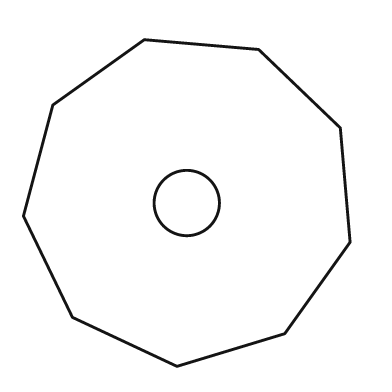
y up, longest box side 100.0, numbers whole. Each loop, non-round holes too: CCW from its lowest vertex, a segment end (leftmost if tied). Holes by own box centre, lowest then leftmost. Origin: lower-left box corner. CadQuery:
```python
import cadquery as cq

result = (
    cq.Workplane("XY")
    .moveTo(47.0, 0.0)
    .lineTo(80.0, 10.0)
    .lineTo(100.0, 38.0)
    .lineTo(97.0, 73.0)
    .lineTo(72.0, 97.0)
    .lineTo(37.0, 100.0)
    .lineTo(9.0, 80.0)
    .lineTo(0.0, 46.0)
    .lineTo(15.0, 15.0)
    .close()
    .moveTo(50.0, 50.0)
    .circle(10.0)
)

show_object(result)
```